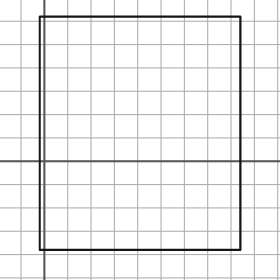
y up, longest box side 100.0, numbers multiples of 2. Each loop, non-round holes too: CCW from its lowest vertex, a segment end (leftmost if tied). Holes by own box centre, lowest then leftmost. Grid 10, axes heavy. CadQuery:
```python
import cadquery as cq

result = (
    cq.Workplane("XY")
    .moveTo(-2.0, -38.0)
    .lineTo(84.0, -38.0)
    .lineTo(84.0, 62.0)
    .lineTo(-2.0, 62.0)
    .close()
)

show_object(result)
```